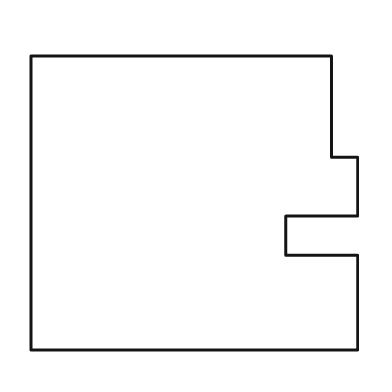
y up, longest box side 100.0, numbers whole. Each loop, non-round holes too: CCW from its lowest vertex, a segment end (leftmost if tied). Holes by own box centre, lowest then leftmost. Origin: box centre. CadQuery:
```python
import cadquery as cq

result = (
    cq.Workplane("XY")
    .moveTo(-50.0, -45.0)
    .lineTo(50.0, -45.0)
    .lineTo(50.0, -16.0)
    .lineTo(28.0, -16.0)
    .lineTo(28.0, -4.0)
    .lineTo(50.0, -4.0)
    .lineTo(50.0, 14.0)
    .lineTo(42.0, 14.0)
    .lineTo(42.0, 45.0)
    .lineTo(-50.0, 45.0)
    .close()
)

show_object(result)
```